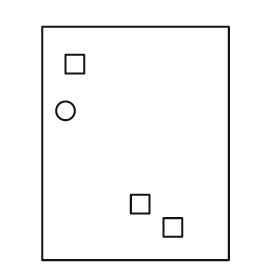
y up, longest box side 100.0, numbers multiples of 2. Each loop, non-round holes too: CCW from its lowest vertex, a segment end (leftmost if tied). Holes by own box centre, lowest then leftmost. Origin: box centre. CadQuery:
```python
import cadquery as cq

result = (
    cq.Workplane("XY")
    .moveTo(-40.0, -50.0)
    .lineTo(40.0, -50.0)
    .lineTo(40.0, 50.0)
    .lineTo(-40.0, 50.0)
    .close()
    .moveTo(12.0, -40.0)
    .lineTo(20.0, -40.0)
    .lineTo(20.0, -32.0)
    .lineTo(12.0, -32.0)
    .close()
    .moveTo(-2.0, -30.0)
    .lineTo(6.0, -30.0)
    .lineTo(6.0, -22.0)
    .lineTo(-2.0, -22.0)
    .close()
    .moveTo(-30.0, 14.0)
    .circle(4.0)
    .moveTo(-30.0, 30.0)
    .lineTo(-22.0, 30.0)
    .lineTo(-22.0, 38.0)
    .lineTo(-30.0, 38.0)
    .close()
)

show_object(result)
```